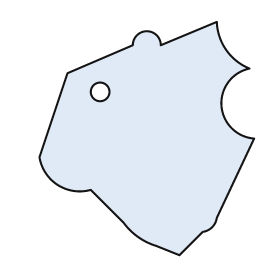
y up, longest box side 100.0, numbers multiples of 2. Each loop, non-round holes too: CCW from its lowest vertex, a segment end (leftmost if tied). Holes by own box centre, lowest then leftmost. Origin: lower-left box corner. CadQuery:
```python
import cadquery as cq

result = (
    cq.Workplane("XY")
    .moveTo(60.0, 0.0)
    .lineTo(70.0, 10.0)
    .threePointArc((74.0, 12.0), (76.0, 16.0))
    .lineTo(92.0, 50.0)
    .threePointArc((78.0, 64.0), (90.0, 80.0))
    .threePointArc((80.0, 88.0), (76.0, 100.0))
    .lineTo(52.0, 90.0)
    .threePointArc((46.0, 96.0), (40.0, 90.0))
    .lineTo(12.0, 78.0)
    .lineTo(0.0, 42.0)
    .threePointArc((8.0, 30.0), (22.0, 28.0))
    .lineTo(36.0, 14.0)
    .threePointArc((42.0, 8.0), (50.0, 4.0))
    .close()
    .moveTo(26.0, 70.0)
    .circle(4.0)
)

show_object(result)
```